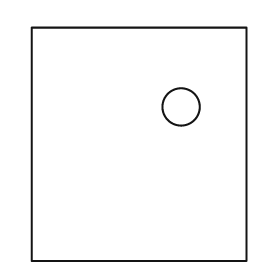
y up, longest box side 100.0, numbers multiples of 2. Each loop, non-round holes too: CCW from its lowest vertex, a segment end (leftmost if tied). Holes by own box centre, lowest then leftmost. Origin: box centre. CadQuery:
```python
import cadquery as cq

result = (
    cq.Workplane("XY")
    .moveTo(-46.0, -50.0)
    .lineTo(46.0, -50.0)
    .lineTo(46.0, 50.0)
    .lineTo(-46.0, 50.0)
    .close()
    .moveTo(18.0, 16.0)
    .circle(8.0)
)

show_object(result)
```